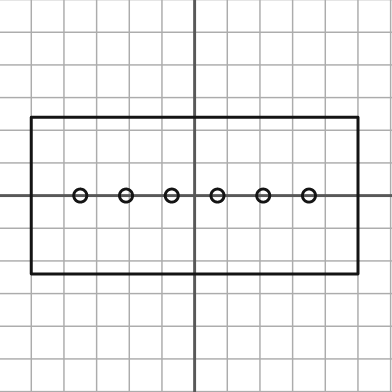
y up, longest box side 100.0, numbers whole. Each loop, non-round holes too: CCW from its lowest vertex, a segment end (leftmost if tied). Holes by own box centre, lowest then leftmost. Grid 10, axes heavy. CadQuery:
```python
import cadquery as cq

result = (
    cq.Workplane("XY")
    .moveTo(-50.0, -24.0)
    .lineTo(50.0, -24.0)
    .lineTo(50.0, 24.0)
    .lineTo(-50.0, 24.0)
    .close()
    .moveTo(-35.0, 0.0)
    .circle(2.0)
    .moveTo(-21.0, 0.0)
    .circle(2.0)
    .moveTo(-7.0, 0.0)
    .circle(2.0)
    .moveTo(7.0, 0.0)
    .circle(2.0)
    .moveTo(21.0, 0.0)
    .circle(2.0)
    .moveTo(35.0, 0.0)
    .circle(2.0)
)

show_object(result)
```